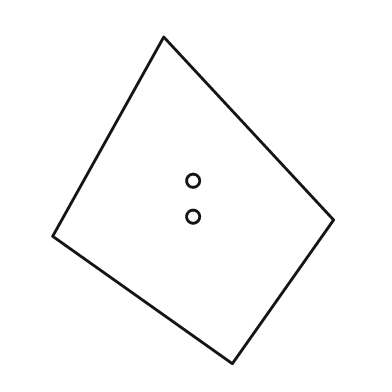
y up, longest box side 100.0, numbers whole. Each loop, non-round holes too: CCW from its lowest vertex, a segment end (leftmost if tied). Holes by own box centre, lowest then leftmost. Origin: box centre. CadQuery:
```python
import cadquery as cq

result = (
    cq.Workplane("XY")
    .moveTo(12.0, -50.0)
    .lineTo(43.0, -6.0)
    .lineTo(-9.0, 50.0)
    .lineTo(-43.0, -11.0)
    .close()
    .moveTo(0.0, -5.0)
    .circle(2.0)
    .moveTo(0.0, 6.0)
    .circle(2.0)
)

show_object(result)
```